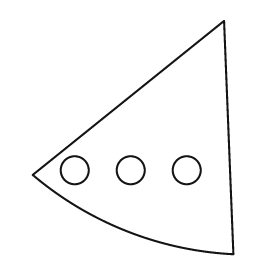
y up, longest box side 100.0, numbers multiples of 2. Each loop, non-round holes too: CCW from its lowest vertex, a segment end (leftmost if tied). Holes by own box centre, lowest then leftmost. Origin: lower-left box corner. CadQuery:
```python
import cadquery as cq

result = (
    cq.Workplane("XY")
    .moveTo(86.0, 0.0)
    .lineTo(82.0, 100.0)
    .lineTo(0.0, 34.0)
    .threePointArc((40.0, 10.0), (86.0, 0.0))
    .close()
    .moveTo(18.0, 36.0)
    .circle(6.0)
    .moveTo(42.0, 36.0)
    .circle(6.0)
    .moveTo(66.0, 36.0)
    .circle(6.0)
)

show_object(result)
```